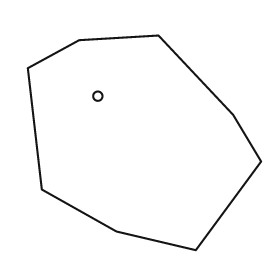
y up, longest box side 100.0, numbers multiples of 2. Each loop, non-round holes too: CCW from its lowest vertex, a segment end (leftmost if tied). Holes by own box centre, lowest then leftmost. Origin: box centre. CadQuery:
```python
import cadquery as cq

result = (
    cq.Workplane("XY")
    .moveTo(22.0, -46.0)
    .lineTo(50.0, -8.0)
    .lineTo(38.0, 12.0)
    .lineTo(6.0, 46.0)
    .lineTo(-28.0, 44.0)
    .lineTo(-50.0, 32.0)
    .lineTo(-44.0, -20.0)
    .lineTo(-12.0, -38.0)
    .close()
    .moveTo(-20.0, 20.0)
    .circle(2.0)
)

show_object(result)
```